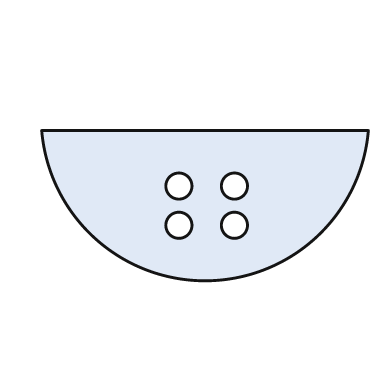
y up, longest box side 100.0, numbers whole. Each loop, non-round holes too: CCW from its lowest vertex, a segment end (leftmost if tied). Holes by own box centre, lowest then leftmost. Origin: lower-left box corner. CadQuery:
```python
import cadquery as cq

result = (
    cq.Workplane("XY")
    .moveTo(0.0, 46.0)
    .threePointArc((50.0, 0.0), (100.0, 46.0))
    .close()
    .moveTo(42.0, 17.0)
    .circle(4.0)
    .moveTo(59.0, 17.0)
    .circle(4.0)
    .moveTo(42.0, 29.0)
    .circle(4.0)
    .moveTo(59.0, 29.0)
    .circle(4.0)
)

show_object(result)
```